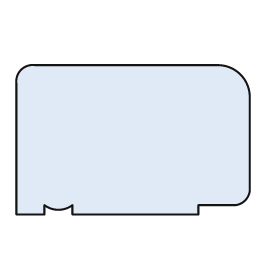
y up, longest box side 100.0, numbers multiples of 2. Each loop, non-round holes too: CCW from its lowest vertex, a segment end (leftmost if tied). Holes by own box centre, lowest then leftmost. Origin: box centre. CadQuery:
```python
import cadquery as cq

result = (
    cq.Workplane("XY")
    .moveTo(-50.0, -32.0)
    .lineTo(-38.0, -32.0)
    .lineTo(-38.0, -28.0)
    .threePointArc((-32.0, -30.0), (-26.0, -28.0))
    .lineTo(-26.0, -32.0)
    .lineTo(28.0, -32.0)
    .lineTo(28.0, -28.0)
    .lineTo(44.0, -28.0)
    .threePointArc((48.0, -26.0), (50.0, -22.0))
    .lineTo(50.0, 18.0)
    .threePointArc((46.0, 28.0), (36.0, 32.0))
    .lineTo(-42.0, 32.0)
    .threePointArc((-48.0, 30.0), (-50.0, 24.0))
    .close()
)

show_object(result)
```